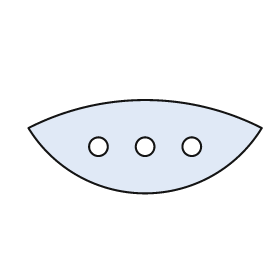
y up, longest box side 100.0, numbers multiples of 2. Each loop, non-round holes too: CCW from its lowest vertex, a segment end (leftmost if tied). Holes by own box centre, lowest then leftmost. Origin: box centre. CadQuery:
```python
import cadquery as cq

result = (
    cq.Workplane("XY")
    .moveTo(-50.0, 8.0)
    .threePointArc((0.0, -20.0), (50.0, 8.0))
    .threePointArc((0.0, 20.0), (-50.0, 8.0))
    .close()
    .moveTo(-20.0, 0.0)
    .circle(4.0)
    .moveTo(0.0, 0.0)
    .circle(4.0)
    .moveTo(20.0, 0.0)
    .circle(4.0)
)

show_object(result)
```